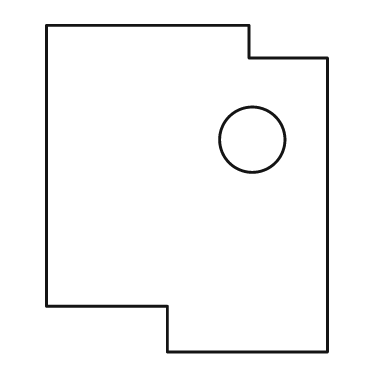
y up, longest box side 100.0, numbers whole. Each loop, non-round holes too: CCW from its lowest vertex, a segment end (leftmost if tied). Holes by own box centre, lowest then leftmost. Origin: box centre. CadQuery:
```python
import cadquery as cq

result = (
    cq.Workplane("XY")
    .moveTo(-6.0, -50.0)
    .lineTo(43.0, -50.0)
    .lineTo(43.0, 40.0)
    .lineTo(19.0, 40.0)
    .lineTo(19.0, 50.0)
    .lineTo(-43.0, 50.0)
    .lineTo(-43.0, -36.0)
    .lineTo(-6.0, -36.0)
    .close()
    .moveTo(20.0, 15.0)
    .circle(10.0)
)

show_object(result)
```